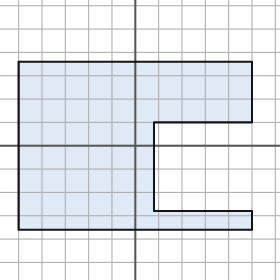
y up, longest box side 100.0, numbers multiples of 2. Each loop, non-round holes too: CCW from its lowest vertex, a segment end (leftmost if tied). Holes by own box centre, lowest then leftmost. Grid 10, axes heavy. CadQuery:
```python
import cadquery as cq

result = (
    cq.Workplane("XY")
    .moveTo(-50.0, -36.0)
    .lineTo(50.0, -36.0)
    .lineTo(50.0, -28.0)
    .lineTo(8.0, -28.0)
    .lineTo(8.0, 10.0)
    .lineTo(50.0, 10.0)
    .lineTo(50.0, 36.0)
    .lineTo(-50.0, 36.0)
    .close()
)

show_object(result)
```